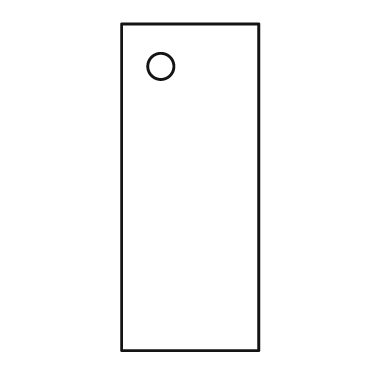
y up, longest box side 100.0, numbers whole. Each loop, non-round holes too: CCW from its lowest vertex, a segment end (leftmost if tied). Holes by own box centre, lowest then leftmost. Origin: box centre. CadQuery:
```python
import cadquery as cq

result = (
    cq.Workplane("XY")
    .moveTo(-21.0, -50.0)
    .lineTo(21.0, -50.0)
    .lineTo(21.0, 50.0)
    .lineTo(-21.0, 50.0)
    .close()
    .moveTo(-9.0, 37.0)
    .circle(4.0)
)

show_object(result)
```